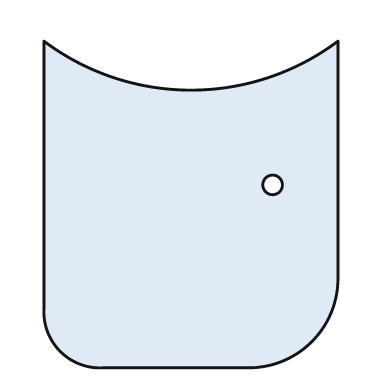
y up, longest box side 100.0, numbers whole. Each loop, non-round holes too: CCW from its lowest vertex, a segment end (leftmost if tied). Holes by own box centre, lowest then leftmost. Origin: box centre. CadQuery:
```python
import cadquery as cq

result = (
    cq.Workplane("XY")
    .moveTo(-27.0, -50.0)
    .lineTo(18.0, -50.0)
    .threePointArc((37.0, -42.0), (45.0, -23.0))
    .lineTo(45.0, 50.0)
    .threePointArc((0.0, 35.0), (-45.0, 50.0))
    .lineTo(-45.0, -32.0)
    .threePointArc((-40.0, -45.0), (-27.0, -50.0))
    .close()
    .moveTo(25.0, 6.0)
    .circle(3.0)
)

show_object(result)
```